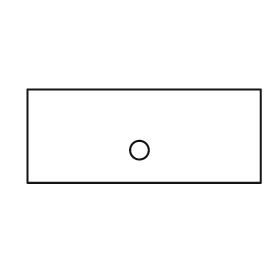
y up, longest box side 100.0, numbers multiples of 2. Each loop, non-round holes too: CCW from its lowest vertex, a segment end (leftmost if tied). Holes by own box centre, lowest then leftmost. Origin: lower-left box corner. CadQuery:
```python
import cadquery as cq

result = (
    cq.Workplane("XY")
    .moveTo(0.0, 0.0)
    .lineTo(100.0, 0.0)
    .lineTo(100.0, 40.0)
    .lineTo(0.0, 40.0)
    .close()
    .moveTo(48.0, 14.0)
    .circle(4.0)
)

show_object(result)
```